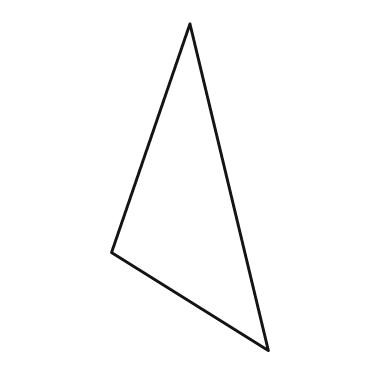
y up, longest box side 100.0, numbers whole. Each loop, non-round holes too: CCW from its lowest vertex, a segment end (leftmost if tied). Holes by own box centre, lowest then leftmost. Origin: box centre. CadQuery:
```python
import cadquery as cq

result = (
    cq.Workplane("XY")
    .moveTo(24.0, -50.0)
    .lineTo(0.0, 50.0)
    .lineTo(-24.0, -20.0)
    .close()
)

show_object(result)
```